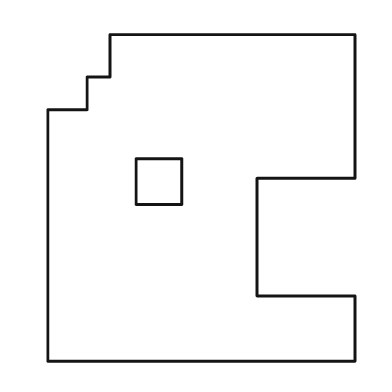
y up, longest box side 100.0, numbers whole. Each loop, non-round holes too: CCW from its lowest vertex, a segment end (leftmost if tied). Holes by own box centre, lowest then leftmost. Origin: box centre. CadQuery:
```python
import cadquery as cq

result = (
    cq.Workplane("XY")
    .moveTo(-47.0, -50.0)
    .lineTo(47.0, -50.0)
    .lineTo(47.0, -30.0)
    .lineTo(17.0, -30.0)
    .lineTo(17.0, 6.0)
    .lineTo(47.0, 6.0)
    .lineTo(47.0, 50.0)
    .lineTo(-28.0, 50.0)
    .lineTo(-28.0, 37.0)
    .lineTo(-35.0, 37.0)
    .lineTo(-35.0, 27.0)
    .lineTo(-47.0, 27.0)
    .close()
    .moveTo(-20.0, -2.0)
    .lineTo(-6.0, -2.0)
    .lineTo(-6.0, 12.0)
    .lineTo(-20.0, 12.0)
    .close()
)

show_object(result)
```